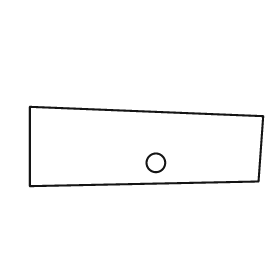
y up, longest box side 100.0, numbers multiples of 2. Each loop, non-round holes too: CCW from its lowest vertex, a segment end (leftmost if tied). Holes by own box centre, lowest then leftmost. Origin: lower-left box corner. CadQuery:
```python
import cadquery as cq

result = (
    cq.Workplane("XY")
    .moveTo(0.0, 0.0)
    .lineTo(98.0, 2.0)
    .lineTo(100.0, 30.0)
    .lineTo(0.0, 34.0)
    .close()
    .moveTo(54.0, 10.0)
    .circle(4.0)
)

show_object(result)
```